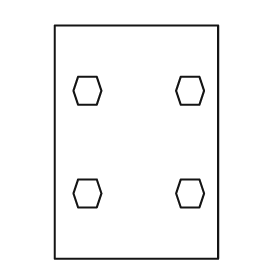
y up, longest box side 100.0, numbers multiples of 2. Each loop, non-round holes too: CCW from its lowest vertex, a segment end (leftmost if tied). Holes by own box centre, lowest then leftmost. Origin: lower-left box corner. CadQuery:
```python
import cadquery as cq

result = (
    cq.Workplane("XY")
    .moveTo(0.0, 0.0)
    .lineTo(70.0, 0.0)
    .lineTo(70.0, 100.0)
    .lineTo(0.0, 100.0)
    .close()
    .moveTo(10.0, 22.0)
    .lineTo(18.0, 22.0)
    .lineTo(20.0, 28.0)
    .lineTo(18.0, 34.0)
    .lineTo(10.0, 34.0)
    .lineTo(8.0, 28.0)
    .close()
    .moveTo(54.0, 22.0)
    .lineTo(62.0, 22.0)
    .lineTo(64.0, 28.0)
    .lineTo(62.0, 34.0)
    .lineTo(54.0, 34.0)
    .lineTo(52.0, 28.0)
    .close()
    .moveTo(10.0, 66.0)
    .lineTo(18.0, 66.0)
    .lineTo(20.0, 72.0)
    .lineTo(18.0, 78.0)
    .lineTo(10.0, 78.0)
    .lineTo(8.0, 72.0)
    .close()
    .moveTo(54.0, 66.0)
    .lineTo(62.0, 66.0)
    .lineTo(64.0, 72.0)
    .lineTo(62.0, 78.0)
    .lineTo(54.0, 78.0)
    .lineTo(52.0, 72.0)
    .close()
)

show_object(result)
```